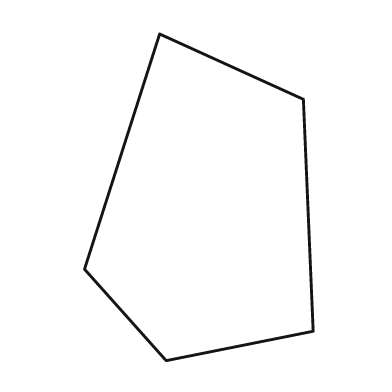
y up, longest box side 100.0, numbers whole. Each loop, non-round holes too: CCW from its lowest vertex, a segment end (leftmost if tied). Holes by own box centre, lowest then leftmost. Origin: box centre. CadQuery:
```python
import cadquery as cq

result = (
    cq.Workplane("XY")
    .moveTo(-10.0, -50.0)
    .lineTo(35.0, -41.0)
    .lineTo(32.0, 30.0)
    .lineTo(-12.0, 50.0)
    .lineTo(-35.0, -22.0)
    .close()
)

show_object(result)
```